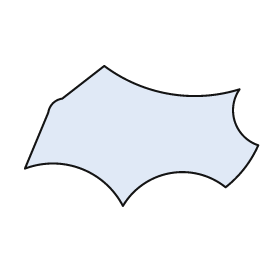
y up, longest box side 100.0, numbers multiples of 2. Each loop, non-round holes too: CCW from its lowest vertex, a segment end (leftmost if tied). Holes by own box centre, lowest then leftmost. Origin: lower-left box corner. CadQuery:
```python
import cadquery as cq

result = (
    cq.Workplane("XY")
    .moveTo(42.0, 0.0)
    .threePointArc((62.0, 14.0), (86.0, 8.0))
    .threePointArc((94.0, 16.0), (100.0, 26.0))
    .threePointArc((90.0, 36.0), (92.0, 50.0))
    .threePointArc((62.0, 48.0), (34.0, 60.0))
    .lineTo(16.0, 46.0)
    .threePointArc((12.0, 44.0), (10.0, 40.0))
    .lineTo(0.0, 16.0)
    .threePointArc((24.0, 16.0), (42.0, 0.0))
    .close()
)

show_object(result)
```